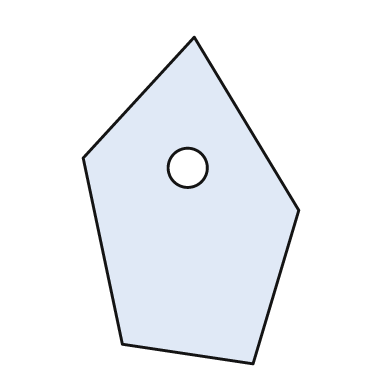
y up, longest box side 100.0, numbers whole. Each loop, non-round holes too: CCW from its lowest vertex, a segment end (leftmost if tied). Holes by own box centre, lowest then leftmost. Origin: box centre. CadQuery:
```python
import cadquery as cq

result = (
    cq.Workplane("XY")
    .moveTo(19.0, -50.0)
    .lineTo(33.0, -3.0)
    .lineTo(1.0, 50.0)
    .lineTo(-33.0, 13.0)
    .lineTo(-21.0, -44.0)
    .close()
    .moveTo(-1.0, 10.0)
    .circle(6.0)
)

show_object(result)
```